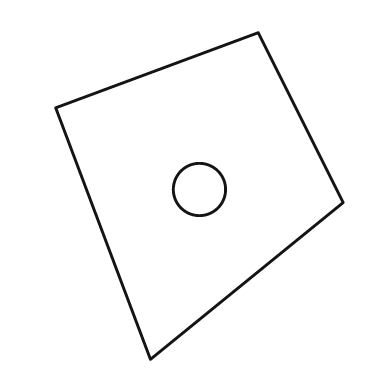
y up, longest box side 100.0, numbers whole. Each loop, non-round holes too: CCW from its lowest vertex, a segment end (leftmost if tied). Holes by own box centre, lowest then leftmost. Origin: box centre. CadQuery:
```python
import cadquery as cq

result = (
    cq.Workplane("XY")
    .moveTo(-15.0, -50.0)
    .lineTo(44.0, -2.0)
    .lineTo(18.0, 50.0)
    .lineTo(-44.0, 27.0)
    .close()
    .moveTo(0.0, 2.0)
    .circle(8.0)
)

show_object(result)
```